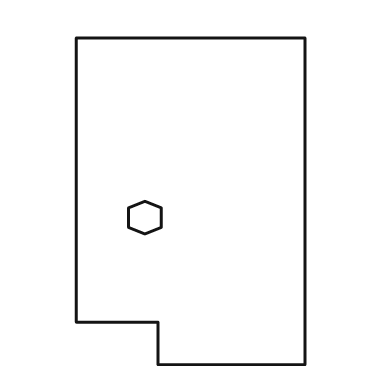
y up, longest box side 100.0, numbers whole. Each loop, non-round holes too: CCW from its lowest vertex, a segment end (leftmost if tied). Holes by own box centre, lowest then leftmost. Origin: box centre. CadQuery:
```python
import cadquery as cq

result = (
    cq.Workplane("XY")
    .moveTo(-10.0, -50.0)
    .lineTo(35.0, -50.0)
    .lineTo(35.0, 50.0)
    .lineTo(-35.0, 50.0)
    .lineTo(-35.0, -37.0)
    .lineTo(-10.0, -37.0)
    .close()
    .moveTo(-14.0, -10.0)
    .lineTo(-9.0, -8.0)
    .lineTo(-9.0, -2.0)
    .lineTo(-14.0, 0.0)
    .lineTo(-19.0, -2.0)
    .lineTo(-19.0, -8.0)
    .close()
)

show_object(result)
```